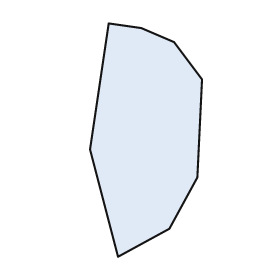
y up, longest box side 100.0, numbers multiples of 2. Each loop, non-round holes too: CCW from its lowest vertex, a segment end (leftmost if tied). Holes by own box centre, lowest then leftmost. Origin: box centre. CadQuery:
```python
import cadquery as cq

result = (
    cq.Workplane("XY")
    .moveTo(-12.0, -50.0)
    .lineTo(10.0, -38.0)
    .lineTo(22.0, -16.0)
    .lineTo(24.0, 26.0)
    .lineTo(12.0, 42.0)
    .lineTo(-2.0, 48.0)
    .lineTo(-16.0, 50.0)
    .lineTo(-24.0, -4.0)
    .close()
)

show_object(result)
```